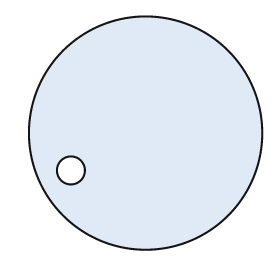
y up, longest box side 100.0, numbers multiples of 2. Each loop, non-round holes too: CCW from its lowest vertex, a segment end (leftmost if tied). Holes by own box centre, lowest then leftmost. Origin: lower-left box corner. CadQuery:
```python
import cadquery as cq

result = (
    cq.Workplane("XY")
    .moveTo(50.0, 50.0)
    .circle(50.0)
    .moveTo(18.0, 34.0)
    .circle(6.0)
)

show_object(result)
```